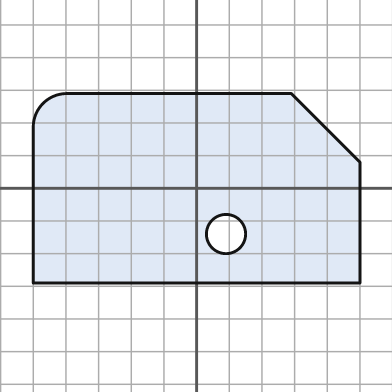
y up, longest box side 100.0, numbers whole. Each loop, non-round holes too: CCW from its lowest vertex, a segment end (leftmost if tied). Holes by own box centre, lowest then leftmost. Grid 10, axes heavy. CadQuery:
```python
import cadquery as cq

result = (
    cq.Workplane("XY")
    .moveTo(-50.0, -29.0)
    .lineTo(50.0, -29.0)
    .lineTo(50.0, 8.0)
    .lineTo(29.0, 29.0)
    .lineTo(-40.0, 29.0)
    .threePointArc((-47.0, 26.0), (-50.0, 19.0))
    .close()
    .moveTo(9.0, -14.0)
    .circle(6.0)
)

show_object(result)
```